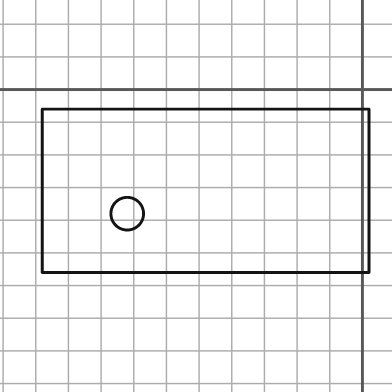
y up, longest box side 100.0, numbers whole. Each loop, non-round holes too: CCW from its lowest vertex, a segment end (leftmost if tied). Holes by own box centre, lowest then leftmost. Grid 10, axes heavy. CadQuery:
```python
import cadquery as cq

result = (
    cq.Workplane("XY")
    .moveTo(-98.0, -56.0)
    .lineTo(2.0, -56.0)
    .lineTo(2.0, -6.0)
    .lineTo(-98.0, -6.0)
    .close()
    .moveTo(-72.0, -38.0)
    .circle(5.0)
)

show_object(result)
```